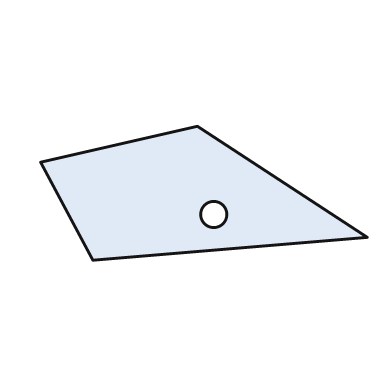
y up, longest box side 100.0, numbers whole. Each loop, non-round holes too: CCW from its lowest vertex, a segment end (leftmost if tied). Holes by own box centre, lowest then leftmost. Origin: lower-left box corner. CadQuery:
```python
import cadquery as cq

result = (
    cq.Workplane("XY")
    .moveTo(16.0, 0.0)
    .lineTo(100.0, 7.0)
    .lineTo(48.0, 41.0)
    .lineTo(0.0, 30.0)
    .close()
    .moveTo(53.0, 14.0)
    .circle(4.0)
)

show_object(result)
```